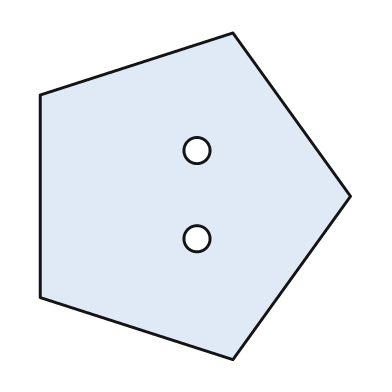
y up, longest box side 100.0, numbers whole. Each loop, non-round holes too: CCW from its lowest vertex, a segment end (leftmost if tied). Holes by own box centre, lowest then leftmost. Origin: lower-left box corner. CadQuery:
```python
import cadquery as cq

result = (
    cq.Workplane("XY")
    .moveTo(59.0, 0.0)
    .lineTo(95.0, 50.0)
    .lineTo(59.0, 100.0)
    .lineTo(0.0, 81.0)
    .lineTo(0.0, 19.0)
    .close()
    .moveTo(48.0, 37.0)
    .circle(4.0)
    .moveTo(48.0, 64.0)
    .circle(4.0)
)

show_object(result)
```